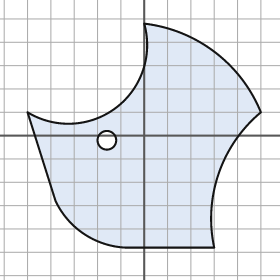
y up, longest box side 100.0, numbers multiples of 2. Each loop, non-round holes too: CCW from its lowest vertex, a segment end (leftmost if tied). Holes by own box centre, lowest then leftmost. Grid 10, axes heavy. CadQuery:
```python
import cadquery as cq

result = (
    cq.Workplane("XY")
    .moveTo(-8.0, -48.0)
    .lineTo(30.0, -48.0)
    .threePointArc((32.0, -16.0), (50.0, 10.0))
    .threePointArc((30.0, 36.0), (0.0, 48.0))
    .threePointArc((-12.0, 12.0), (-50.0, 10.0))
    .lineTo(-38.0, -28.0)
    .threePointArc((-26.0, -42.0), (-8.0, -48.0))
    .close()
    .moveTo(-16.0, -2.0)
    .circle(4.0)
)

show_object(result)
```